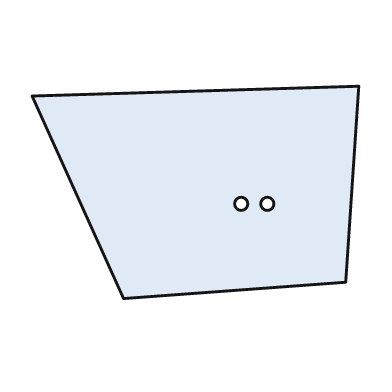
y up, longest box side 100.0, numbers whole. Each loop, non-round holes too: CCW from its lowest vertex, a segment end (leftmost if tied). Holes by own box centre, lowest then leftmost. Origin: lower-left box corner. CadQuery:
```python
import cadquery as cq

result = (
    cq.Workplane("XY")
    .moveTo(28.0, 0.0)
    .lineTo(96.0, 5.0)
    .lineTo(100.0, 65.0)
    .lineTo(0.0, 62.0)
    .close()
    .moveTo(64.0, 29.0)
    .circle(2.0)
    .moveTo(72.0, 29.0)
    .circle(2.0)
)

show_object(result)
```